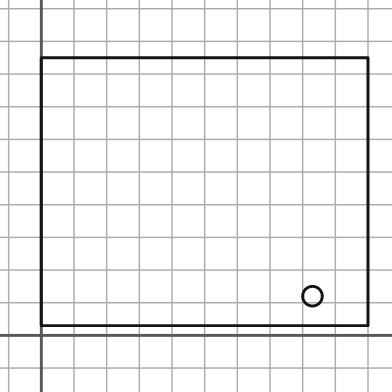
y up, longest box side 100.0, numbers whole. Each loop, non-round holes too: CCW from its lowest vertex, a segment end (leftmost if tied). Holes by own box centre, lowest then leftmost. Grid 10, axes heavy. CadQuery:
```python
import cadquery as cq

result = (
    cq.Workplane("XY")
    .moveTo(0.0, 3.0)
    .lineTo(100.0, 3.0)
    .lineTo(100.0, 85.0)
    .lineTo(0.0, 85.0)
    .close()
    .moveTo(83.0, 12.0)
    .circle(3.0)
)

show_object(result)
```